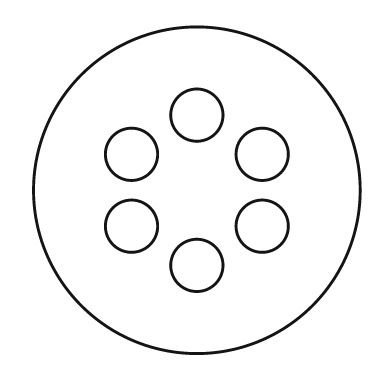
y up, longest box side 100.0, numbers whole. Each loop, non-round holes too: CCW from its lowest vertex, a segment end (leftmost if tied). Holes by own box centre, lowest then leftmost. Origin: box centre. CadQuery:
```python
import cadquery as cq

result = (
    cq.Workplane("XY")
    .moveTo(0.0, 0.0)
    .circle(50.0)
    .moveTo(0.0, -23.0)
    .circle(8.0)
    .moveTo(-20.0, -11.0)
    .circle(8.0)
    .moveTo(20.0, -11.0)
    .circle(8.0)
    .moveTo(-20.0, 11.0)
    .circle(8.0)
    .moveTo(20.0, 11.0)
    .circle(8.0)
    .moveTo(0.0, 23.0)
    .circle(8.0)
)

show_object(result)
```